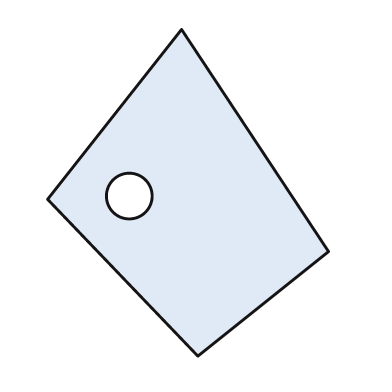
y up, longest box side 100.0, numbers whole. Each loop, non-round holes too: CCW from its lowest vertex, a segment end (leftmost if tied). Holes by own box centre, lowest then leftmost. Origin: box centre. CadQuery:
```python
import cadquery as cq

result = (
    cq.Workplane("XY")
    .moveTo(3.0, -50.0)
    .lineTo(43.0, -18.0)
    .lineTo(-2.0, 50.0)
    .lineTo(-43.0, -2.0)
    .close()
    .moveTo(-18.0, -1.0)
    .circle(7.0)
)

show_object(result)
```